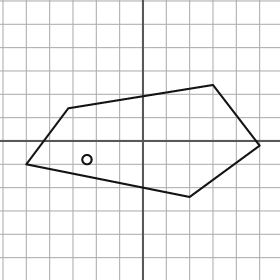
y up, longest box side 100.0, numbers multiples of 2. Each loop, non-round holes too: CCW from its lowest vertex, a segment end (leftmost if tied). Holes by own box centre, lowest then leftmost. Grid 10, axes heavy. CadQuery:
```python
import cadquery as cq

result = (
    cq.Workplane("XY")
    .moveTo(20.0, -24.0)
    .lineTo(50.0, -2.0)
    .lineTo(30.0, 24.0)
    .lineTo(-32.0, 14.0)
    .lineTo(-50.0, -10.0)
    .close()
    .moveTo(-24.0, -8.0)
    .circle(2.0)
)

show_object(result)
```